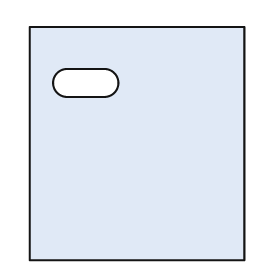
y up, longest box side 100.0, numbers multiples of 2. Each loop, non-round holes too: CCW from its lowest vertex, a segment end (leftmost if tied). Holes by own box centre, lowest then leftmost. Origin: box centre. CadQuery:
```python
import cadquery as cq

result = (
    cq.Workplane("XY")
    .moveTo(-46.0, -50.0)
    .lineTo(46.0, -50.0)
    .lineTo(46.0, 50.0)
    .lineTo(-46.0, 50.0)
    .close()
    .moveTo(-30.0, 20.0)
    .lineTo(-14.0, 20.0)
    .threePointArc((-8.0, 26.0), (-14.0, 32.0))
    .lineTo(-30.0, 32.0)
    .threePointArc((-36.0, 26.0), (-30.0, 20.0))
    .close()
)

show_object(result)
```